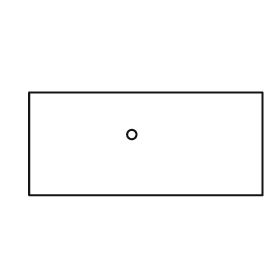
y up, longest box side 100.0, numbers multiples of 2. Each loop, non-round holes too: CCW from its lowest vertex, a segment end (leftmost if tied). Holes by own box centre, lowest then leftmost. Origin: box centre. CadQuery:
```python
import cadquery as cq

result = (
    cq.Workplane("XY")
    .moveTo(-50.0, -22.0)
    .lineTo(50.0, -22.0)
    .lineTo(50.0, 22.0)
    .lineTo(-50.0, 22.0)
    .close()
    .moveTo(-6.0, 4.0)
    .circle(2.0)
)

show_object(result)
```